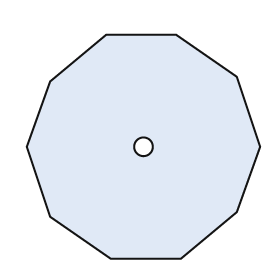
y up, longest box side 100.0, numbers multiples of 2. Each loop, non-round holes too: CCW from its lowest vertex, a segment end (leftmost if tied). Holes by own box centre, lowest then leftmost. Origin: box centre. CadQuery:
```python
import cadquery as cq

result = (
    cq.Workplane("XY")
    .moveTo(-14.0, -48.0)
    .lineTo(16.0, -48.0)
    .lineTo(40.0, -28.0)
    .lineTo(50.0, 0.0)
    .lineTo(40.0, 30.0)
    .lineTo(14.0, 48.0)
    .lineTo(-16.0, 48.0)
    .lineTo(-40.0, 28.0)
    .lineTo(-50.0, 0.0)
    .lineTo(-40.0, -30.0)
    .close()
    .moveTo(0.0, 0.0)
    .circle(4.0)
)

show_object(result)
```